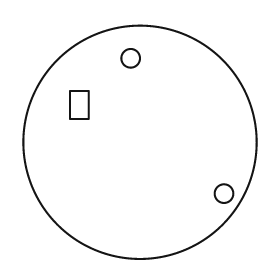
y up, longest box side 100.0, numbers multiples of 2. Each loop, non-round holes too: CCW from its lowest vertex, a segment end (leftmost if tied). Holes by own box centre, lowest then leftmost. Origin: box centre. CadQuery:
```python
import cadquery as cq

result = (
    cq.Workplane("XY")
    .moveTo(0.0, 0.0)
    .circle(50.0)
    .moveTo(36.0, -22.0)
    .circle(4.0)
    .moveTo(-30.0, 10.0)
    .lineTo(-22.0, 10.0)
    .lineTo(-22.0, 22.0)
    .lineTo(-30.0, 22.0)
    .close()
    .moveTo(-4.0, 36.0)
    .circle(4.0)
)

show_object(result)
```